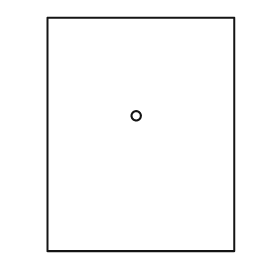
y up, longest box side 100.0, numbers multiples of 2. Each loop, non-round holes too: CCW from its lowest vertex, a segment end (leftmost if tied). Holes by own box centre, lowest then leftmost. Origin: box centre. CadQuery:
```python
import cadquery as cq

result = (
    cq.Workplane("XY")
    .moveTo(-40.0, -50.0)
    .lineTo(40.0, -50.0)
    .lineTo(40.0, 50.0)
    .lineTo(-40.0, 50.0)
    .close()
    .moveTo(-2.0, 8.0)
    .circle(2.0)
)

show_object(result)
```